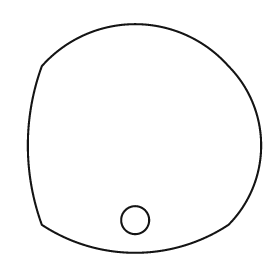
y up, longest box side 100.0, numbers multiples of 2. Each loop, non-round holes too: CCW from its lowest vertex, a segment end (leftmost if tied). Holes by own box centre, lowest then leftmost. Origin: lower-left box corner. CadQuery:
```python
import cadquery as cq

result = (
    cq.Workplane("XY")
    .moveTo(6.0, 12.0)
    .threePointArc((46.0, 0.0), (86.0, 12.0))
    .threePointArc((100.0, 46.0), (86.0, 80.0))
    .threePointArc((46.0, 98.0), (6.0, 80.0))
    .threePointArc((0.0, 46.0), (6.0, 12.0))
    .close()
    .moveTo(46.0, 14.0)
    .circle(6.0)
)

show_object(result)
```